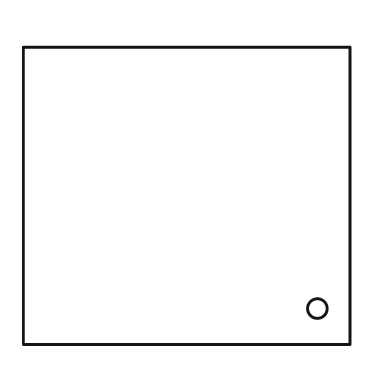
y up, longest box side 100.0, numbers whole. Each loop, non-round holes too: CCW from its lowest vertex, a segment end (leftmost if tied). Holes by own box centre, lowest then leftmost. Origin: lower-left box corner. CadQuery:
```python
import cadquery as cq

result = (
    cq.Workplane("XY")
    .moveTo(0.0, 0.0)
    .lineTo(100.0, 0.0)
    .lineTo(100.0, 91.0)
    .lineTo(0.0, 91.0)
    .close()
    .moveTo(90.0, 11.0)
    .circle(3.0)
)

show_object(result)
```